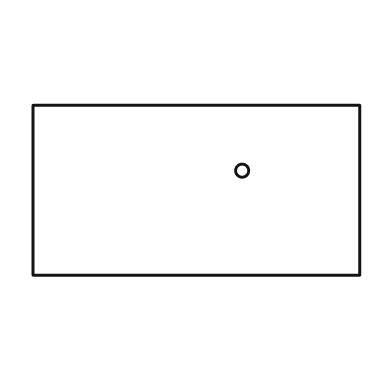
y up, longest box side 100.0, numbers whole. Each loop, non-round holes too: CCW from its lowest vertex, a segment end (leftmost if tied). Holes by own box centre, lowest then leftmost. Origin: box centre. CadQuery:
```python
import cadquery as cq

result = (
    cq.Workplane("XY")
    .moveTo(-50.0, -26.0)
    .lineTo(50.0, -26.0)
    .lineTo(50.0, 26.0)
    .lineTo(-50.0, 26.0)
    .close()
    .moveTo(14.0, 6.0)
    .circle(2.0)
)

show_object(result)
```